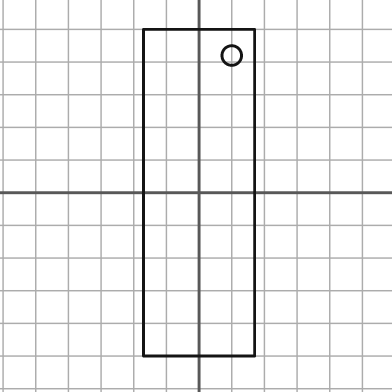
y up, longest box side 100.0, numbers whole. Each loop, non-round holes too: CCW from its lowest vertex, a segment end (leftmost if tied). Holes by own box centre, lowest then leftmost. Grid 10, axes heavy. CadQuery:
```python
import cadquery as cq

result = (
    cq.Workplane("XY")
    .moveTo(-17.0, -50.0)
    .lineTo(17.0, -50.0)
    .lineTo(17.0, 50.0)
    .lineTo(-17.0, 50.0)
    .close()
    .moveTo(10.0, 42.0)
    .circle(3.0)
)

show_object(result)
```